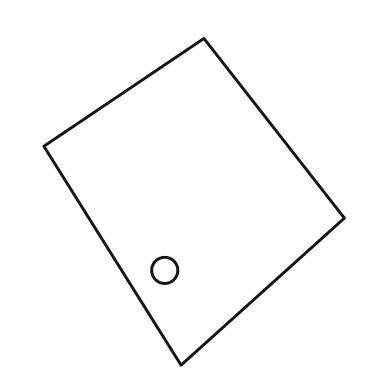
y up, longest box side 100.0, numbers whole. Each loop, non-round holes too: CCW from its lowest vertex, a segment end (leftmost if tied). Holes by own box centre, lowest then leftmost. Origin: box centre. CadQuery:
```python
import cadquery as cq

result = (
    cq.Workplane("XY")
    .moveTo(-4.0, -50.0)
    .lineTo(46.0, -5.0)
    .lineTo(3.0, 50.0)
    .lineTo(-46.0, 17.0)
    .close()
    .moveTo(-9.0, -21.0)
    .circle(4.0)
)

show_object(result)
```